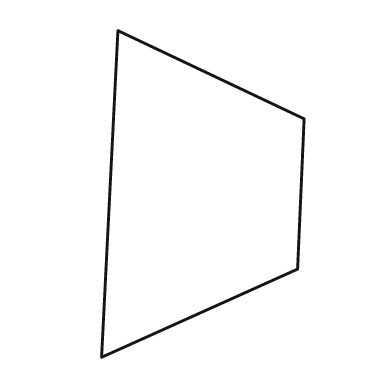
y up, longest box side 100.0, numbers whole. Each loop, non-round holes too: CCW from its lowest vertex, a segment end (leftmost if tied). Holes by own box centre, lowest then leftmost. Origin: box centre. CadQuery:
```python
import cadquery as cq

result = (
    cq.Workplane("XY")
    .moveTo(-31.0, -50.0)
    .lineTo(29.0, -23.0)
    .lineTo(31.0, 23.0)
    .lineTo(-26.0, 50.0)
    .close()
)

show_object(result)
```